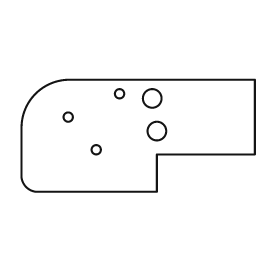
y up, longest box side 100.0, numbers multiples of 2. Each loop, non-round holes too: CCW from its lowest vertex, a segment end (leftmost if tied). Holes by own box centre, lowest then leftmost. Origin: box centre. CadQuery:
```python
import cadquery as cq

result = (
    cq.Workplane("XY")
    .moveTo(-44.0, -24.0)
    .lineTo(8.0, -24.0)
    .lineTo(8.0, -8.0)
    .lineTo(50.0, -8.0)
    .lineTo(50.0, 24.0)
    .lineTo(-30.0, 24.0)
    .threePointArc((-44.0, 18.0), (-50.0, 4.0))
    .lineTo(-50.0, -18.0)
    .threePointArc((-48.0, -22.0), (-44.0, -24.0))
    .close()
    .moveTo(-18.0, -6.0)
    .circle(2.0)
    .moveTo(8.0, 2.0)
    .circle(4.0)
    .moveTo(-30.0, 8.0)
    .circle(2.0)
    .moveTo(6.0, 16.0)
    .circle(4.0)
    .moveTo(-8.0, 18.0)
    .circle(2.0)
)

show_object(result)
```